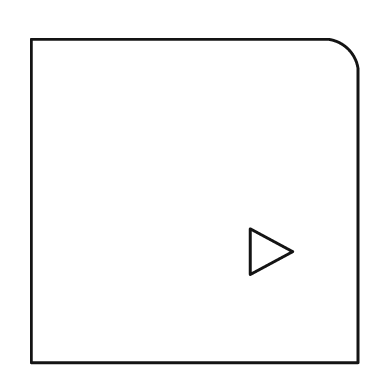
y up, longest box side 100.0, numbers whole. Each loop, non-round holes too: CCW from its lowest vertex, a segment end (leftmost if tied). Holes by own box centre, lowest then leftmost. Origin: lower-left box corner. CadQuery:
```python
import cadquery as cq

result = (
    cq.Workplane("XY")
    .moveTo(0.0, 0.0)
    .lineTo(100.0, 0.0)
    .lineTo(100.0, 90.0)
    .threePointArc((97.0, 96.0), (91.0, 99.0))
    .lineTo(0.0, 99.0)
    .close()
    .moveTo(67.0, 27.0)
    .lineTo(80.0, 34.0)
    .lineTo(67.0, 41.0)
    .close()
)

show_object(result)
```